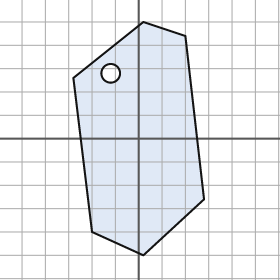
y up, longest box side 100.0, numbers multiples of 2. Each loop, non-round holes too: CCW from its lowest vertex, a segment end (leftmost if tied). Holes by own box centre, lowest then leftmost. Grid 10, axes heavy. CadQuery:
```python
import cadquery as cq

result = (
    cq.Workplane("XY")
    .moveTo(2.0, -50.0)
    .lineTo(28.0, -26.0)
    .lineTo(20.0, 44.0)
    .lineTo(2.0, 50.0)
    .lineTo(-28.0, 26.0)
    .lineTo(-20.0, -40.0)
    .close()
    .moveTo(-12.0, 28.0)
    .circle(4.0)
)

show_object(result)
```